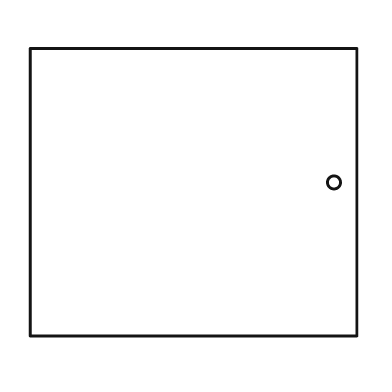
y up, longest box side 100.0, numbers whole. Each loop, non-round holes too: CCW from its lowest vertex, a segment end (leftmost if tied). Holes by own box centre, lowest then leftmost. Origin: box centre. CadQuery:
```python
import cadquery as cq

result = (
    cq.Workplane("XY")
    .moveTo(-50.0, -44.0)
    .lineTo(50.0, -44.0)
    .lineTo(50.0, 44.0)
    .lineTo(-50.0, 44.0)
    .close()
    .moveTo(43.0, 3.0)
    .circle(2.0)
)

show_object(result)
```